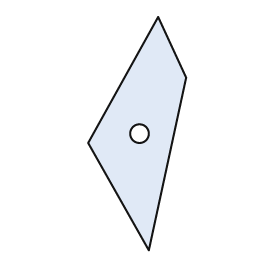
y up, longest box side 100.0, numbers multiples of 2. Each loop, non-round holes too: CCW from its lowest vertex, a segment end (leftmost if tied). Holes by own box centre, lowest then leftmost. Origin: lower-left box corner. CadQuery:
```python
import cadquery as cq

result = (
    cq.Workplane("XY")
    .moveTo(26.0, 0.0)
    .lineTo(42.0, 74.0)
    .lineTo(30.0, 100.0)
    .lineTo(0.0, 46.0)
    .close()
    .moveTo(22.0, 50.0)
    .circle(4.0)
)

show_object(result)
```